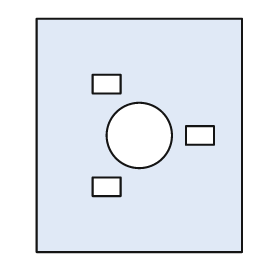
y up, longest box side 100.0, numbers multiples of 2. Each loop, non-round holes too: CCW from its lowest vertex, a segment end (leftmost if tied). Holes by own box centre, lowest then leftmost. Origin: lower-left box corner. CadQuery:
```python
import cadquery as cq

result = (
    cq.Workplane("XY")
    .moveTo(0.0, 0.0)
    .lineTo(88.0, 0.0)
    .lineTo(88.0, 100.0)
    .lineTo(0.0, 100.0)
    .close()
    .moveTo(24.0, 24.0)
    .lineTo(36.0, 24.0)
    .lineTo(36.0, 32.0)
    .lineTo(24.0, 32.0)
    .close()
    .moveTo(44.0, 50.0)
    .circle(14.0)
    .moveTo(64.0, 46.0)
    .lineTo(76.0, 46.0)
    .lineTo(76.0, 54.0)
    .lineTo(64.0, 54.0)
    .close()
    .moveTo(24.0, 68.0)
    .lineTo(36.0, 68.0)
    .lineTo(36.0, 76.0)
    .lineTo(24.0, 76.0)
    .close()
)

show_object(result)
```